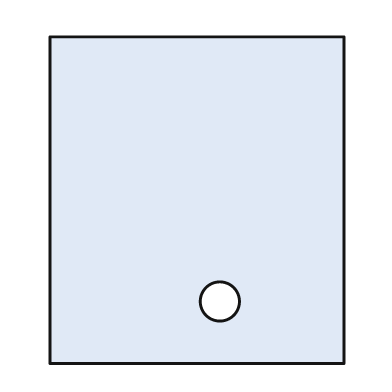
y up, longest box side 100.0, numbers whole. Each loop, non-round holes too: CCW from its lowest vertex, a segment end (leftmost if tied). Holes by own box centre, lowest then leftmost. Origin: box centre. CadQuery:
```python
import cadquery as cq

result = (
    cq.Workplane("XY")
    .moveTo(-45.0, -50.0)
    .lineTo(45.0, -50.0)
    .lineTo(45.0, 50.0)
    .lineTo(-45.0, 50.0)
    .close()
    .moveTo(7.0, -31.0)
    .circle(6.0)
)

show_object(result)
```